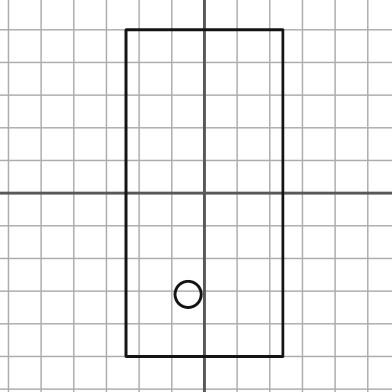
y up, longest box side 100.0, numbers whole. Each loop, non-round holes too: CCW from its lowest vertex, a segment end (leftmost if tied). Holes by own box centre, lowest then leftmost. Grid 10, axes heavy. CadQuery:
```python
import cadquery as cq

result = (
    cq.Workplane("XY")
    .moveTo(-24.0, -50.0)
    .lineTo(24.0, -50.0)
    .lineTo(24.0, 50.0)
    .lineTo(-24.0, 50.0)
    .close()
    .moveTo(-5.0, -31.0)
    .circle(4.0)
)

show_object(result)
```